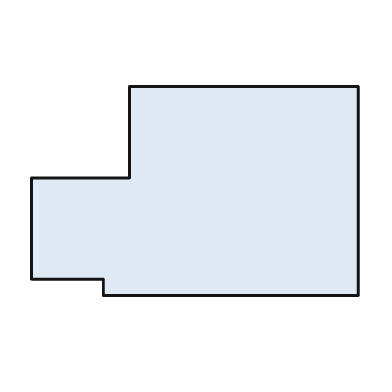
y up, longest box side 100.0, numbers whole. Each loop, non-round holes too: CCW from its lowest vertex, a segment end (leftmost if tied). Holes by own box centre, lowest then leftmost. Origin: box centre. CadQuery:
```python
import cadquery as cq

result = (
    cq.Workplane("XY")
    .moveTo(-28.0, -32.0)
    .lineTo(50.0, -32.0)
    .lineTo(50.0, 32.0)
    .lineTo(-20.0, 32.0)
    .lineTo(-20.0, 4.0)
    .lineTo(-50.0, 4.0)
    .lineTo(-50.0, -27.0)
    .lineTo(-28.0, -27.0)
    .close()
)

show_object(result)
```